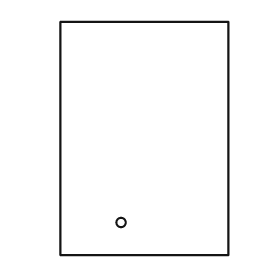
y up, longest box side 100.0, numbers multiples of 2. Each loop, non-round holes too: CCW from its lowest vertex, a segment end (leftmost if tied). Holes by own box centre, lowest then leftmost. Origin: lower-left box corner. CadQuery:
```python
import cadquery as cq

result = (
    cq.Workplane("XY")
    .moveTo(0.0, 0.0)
    .lineTo(72.0, 0.0)
    .lineTo(72.0, 100.0)
    .lineTo(0.0, 100.0)
    .close()
    .moveTo(26.0, 14.0)
    .circle(2.0)
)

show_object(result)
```